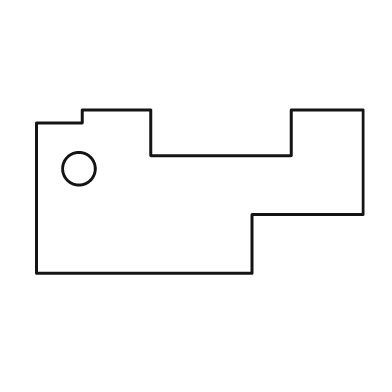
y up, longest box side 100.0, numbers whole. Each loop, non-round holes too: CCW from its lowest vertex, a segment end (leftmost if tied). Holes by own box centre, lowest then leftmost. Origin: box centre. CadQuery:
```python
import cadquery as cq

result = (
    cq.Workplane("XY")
    .moveTo(-50.0, -25.0)
    .lineTo(16.0, -25.0)
    .lineTo(16.0, -7.0)
    .lineTo(50.0, -7.0)
    .lineTo(50.0, 25.0)
    .lineTo(28.0, 25.0)
    .lineTo(28.0, 11.0)
    .lineTo(-15.0, 11.0)
    .lineTo(-15.0, 25.0)
    .lineTo(-36.0, 25.0)
    .lineTo(-36.0, 21.0)
    .lineTo(-50.0, 21.0)
    .close()
    .moveTo(-37.0, 7.0)
    .circle(5.0)
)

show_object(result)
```